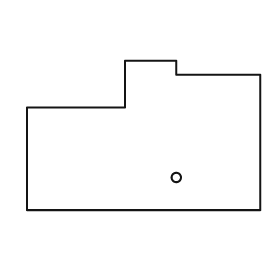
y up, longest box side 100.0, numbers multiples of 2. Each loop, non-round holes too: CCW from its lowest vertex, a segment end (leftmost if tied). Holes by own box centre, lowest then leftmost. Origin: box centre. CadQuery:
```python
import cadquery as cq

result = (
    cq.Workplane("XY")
    .moveTo(-50.0, -32.0)
    .lineTo(50.0, -32.0)
    .lineTo(50.0, 26.0)
    .lineTo(14.0, 26.0)
    .lineTo(14.0, 32.0)
    .lineTo(-8.0, 32.0)
    .lineTo(-8.0, 12.0)
    .lineTo(-50.0, 12.0)
    .close()
    .moveTo(14.0, -18.0)
    .circle(2.0)
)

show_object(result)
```